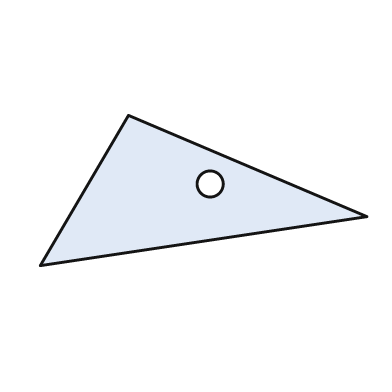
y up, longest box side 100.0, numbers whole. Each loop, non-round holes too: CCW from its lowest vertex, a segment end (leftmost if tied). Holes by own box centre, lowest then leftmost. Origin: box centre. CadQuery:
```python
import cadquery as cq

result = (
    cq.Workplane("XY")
    .moveTo(-50.0, -23.0)
    .lineTo(50.0, -8.0)
    .lineTo(-23.0, 23.0)
    .close()
    .moveTo(2.0, 2.0)
    .circle(4.0)
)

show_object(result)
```